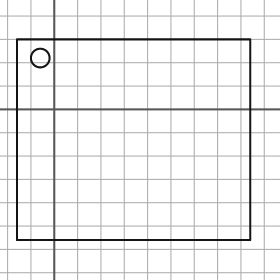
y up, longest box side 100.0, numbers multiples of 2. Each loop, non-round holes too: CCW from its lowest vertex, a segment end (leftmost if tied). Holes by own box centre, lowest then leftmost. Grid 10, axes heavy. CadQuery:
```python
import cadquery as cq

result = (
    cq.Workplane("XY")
    .moveTo(-16.0, -56.0)
    .lineTo(84.0, -56.0)
    .lineTo(84.0, 30.0)
    .lineTo(-16.0, 30.0)
    .close()
    .moveTo(-6.0, 22.0)
    .circle(4.0)
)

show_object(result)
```